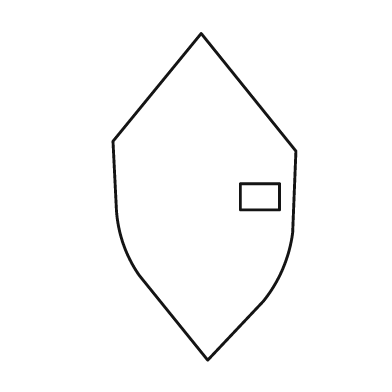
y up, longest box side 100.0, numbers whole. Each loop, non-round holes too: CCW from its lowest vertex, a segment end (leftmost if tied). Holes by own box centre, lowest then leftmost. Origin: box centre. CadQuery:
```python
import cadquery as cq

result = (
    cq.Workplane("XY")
    .moveTo(1.0, -50.0)
    .lineTo(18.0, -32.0)
    .threePointArc((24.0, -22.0), (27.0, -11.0))
    .lineTo(28.0, 14.0)
    .lineTo(-1.0, 50.0)
    .lineTo(-28.0, 17.0)
    .lineTo(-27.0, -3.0)
    .threePointArc((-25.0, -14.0), (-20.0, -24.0))
    .close()
    .moveTo(11.0, -4.0)
    .lineTo(23.0, -4.0)
    .lineTo(23.0, 4.0)
    .lineTo(11.0, 4.0)
    .close()
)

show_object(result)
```